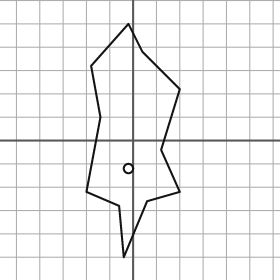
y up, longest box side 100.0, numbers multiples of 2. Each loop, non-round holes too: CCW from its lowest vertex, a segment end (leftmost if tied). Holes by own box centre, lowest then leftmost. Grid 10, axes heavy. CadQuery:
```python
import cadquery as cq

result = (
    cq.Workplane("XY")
    .moveTo(-4.0, -50.0)
    .lineTo(6.0, -26.0)
    .lineTo(20.0, -22.0)
    .lineTo(12.0, -4.0)
    .lineTo(20.0, 22.0)
    .lineTo(4.0, 38.0)
    .lineTo(-2.0, 50.0)
    .lineTo(-18.0, 32.0)
    .lineTo(-14.0, 10.0)
    .lineTo(-20.0, -22.0)
    .lineTo(-6.0, -28.0)
    .close()
    .moveTo(-2.0, -12.0)
    .circle(2.0)
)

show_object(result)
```